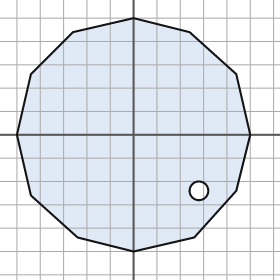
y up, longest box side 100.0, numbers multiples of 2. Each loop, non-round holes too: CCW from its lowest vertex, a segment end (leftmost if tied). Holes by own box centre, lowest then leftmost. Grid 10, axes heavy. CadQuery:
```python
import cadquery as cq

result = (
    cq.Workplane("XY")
    .moveTo(0.0, -50.0)
    .lineTo(26.0, -44.0)
    .lineTo(44.0, -24.0)
    .lineTo(50.0, 0.0)
    .lineTo(44.0, 26.0)
    .lineTo(24.0, 44.0)
    .lineTo(0.0, 50.0)
    .lineTo(-26.0, 44.0)
    .lineTo(-44.0, 26.0)
    .lineTo(-50.0, 0.0)
    .lineTo(-44.0, -26.0)
    .lineTo(-24.0, -44.0)
    .close()
    .moveTo(28.0, -24.0)
    .circle(4.0)
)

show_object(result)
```